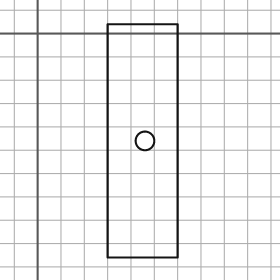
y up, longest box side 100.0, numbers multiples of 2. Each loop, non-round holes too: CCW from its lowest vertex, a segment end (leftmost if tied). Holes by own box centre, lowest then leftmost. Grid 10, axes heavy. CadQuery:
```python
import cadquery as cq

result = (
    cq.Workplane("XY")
    .moveTo(30.0, -96.0)
    .lineTo(60.0, -96.0)
    .lineTo(60.0, 4.0)
    .lineTo(30.0, 4.0)
    .close()
    .moveTo(46.0, -46.0)
    .circle(4.0)
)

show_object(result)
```